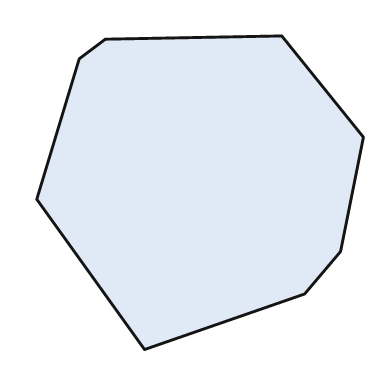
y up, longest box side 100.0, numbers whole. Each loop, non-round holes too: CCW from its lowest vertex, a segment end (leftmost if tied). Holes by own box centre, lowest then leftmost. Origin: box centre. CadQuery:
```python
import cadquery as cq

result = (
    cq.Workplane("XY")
    .moveTo(-17.0, -48.0)
    .lineTo(32.0, -31.0)
    .lineTo(43.0, -18.0)
    .lineTo(50.0, 17.0)
    .lineTo(25.0, 48.0)
    .lineTo(-29.0, 47.0)
    .lineTo(-37.0, 41.0)
    .lineTo(-50.0, -2.0)
    .close()
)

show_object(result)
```